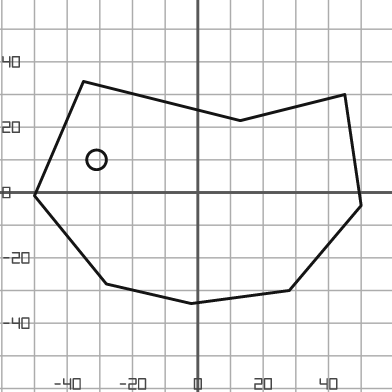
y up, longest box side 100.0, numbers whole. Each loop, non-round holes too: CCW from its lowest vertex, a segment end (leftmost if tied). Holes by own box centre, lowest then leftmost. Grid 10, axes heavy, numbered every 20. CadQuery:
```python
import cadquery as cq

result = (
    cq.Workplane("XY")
    .moveTo(-2.0, -34.0)
    .lineTo(28.0, -30.0)
    .lineTo(50.0, -4.0)
    .lineTo(45.0, 30.0)
    .lineTo(13.0, 22.0)
    .lineTo(-35.0, 34.0)
    .lineTo(-50.0, -1.0)
    .lineTo(-28.0, -28.0)
    .close()
    .moveTo(-31.0, 10.0)
    .circle(3.0)
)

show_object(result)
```